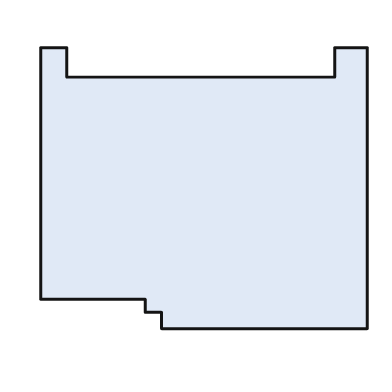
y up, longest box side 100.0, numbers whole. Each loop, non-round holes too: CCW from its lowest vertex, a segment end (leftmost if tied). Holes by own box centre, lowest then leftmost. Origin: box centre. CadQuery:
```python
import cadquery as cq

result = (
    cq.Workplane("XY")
    .moveTo(-13.0, -43.0)
    .lineTo(50.0, -43.0)
    .lineTo(50.0, 43.0)
    .lineTo(40.0, 43.0)
    .lineTo(40.0, 34.0)
    .lineTo(-42.0, 34.0)
    .lineTo(-42.0, 43.0)
    .lineTo(-50.0, 43.0)
    .lineTo(-50.0, -34.0)
    .lineTo(-18.0, -34.0)
    .lineTo(-18.0, -38.0)
    .lineTo(-13.0, -38.0)
    .close()
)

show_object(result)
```